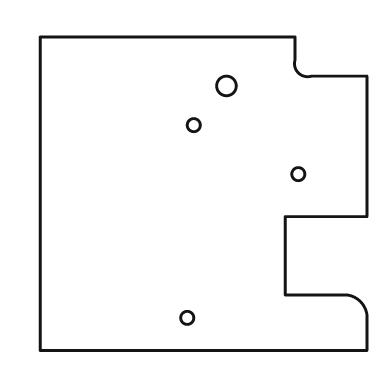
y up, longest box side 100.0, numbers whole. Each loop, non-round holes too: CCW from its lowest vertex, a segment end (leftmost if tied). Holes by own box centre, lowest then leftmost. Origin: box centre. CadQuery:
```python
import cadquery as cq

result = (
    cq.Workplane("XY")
    .moveTo(-50.0, -48.0)
    .lineTo(50.0, -48.0)
    .lineTo(50.0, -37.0)
    .threePointArc((48.0, -33.0), (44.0, -31.0))
    .lineTo(25.0, -31.0)
    .lineTo(25.0, -7.0)
    .lineTo(50.0, -7.0)
    .lineTo(50.0, 36.0)
    .lineTo(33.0, 36.0)
    .threePointArc((29.0, 37.0), (28.0, 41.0))
    .lineTo(28.0, 48.0)
    .lineTo(-50.0, 48.0)
    .close()
    .moveTo(-5.0, -38.0)
    .circle(2.0)
    .moveTo(29.0, 6.0)
    .circle(2.0)
    .moveTo(-3.0, 21.0)
    .circle(2.0)
    .moveTo(7.0, 33.0)
    .circle(3.0)
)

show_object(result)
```